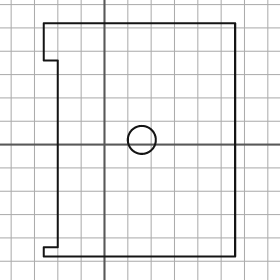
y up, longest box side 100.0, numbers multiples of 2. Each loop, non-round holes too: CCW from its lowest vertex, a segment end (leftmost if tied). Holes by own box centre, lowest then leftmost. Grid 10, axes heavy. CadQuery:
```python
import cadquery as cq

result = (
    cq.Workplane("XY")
    .moveTo(-26.0, -48.0)
    .lineTo(56.0, -48.0)
    .lineTo(56.0, 52.0)
    .lineTo(-26.0, 52.0)
    .lineTo(-26.0, 36.0)
    .lineTo(-20.0, 36.0)
    .lineTo(-20.0, -44.0)
    .lineTo(-26.0, -44.0)
    .close()
    .moveTo(16.0, 2.0)
    .circle(6.0)
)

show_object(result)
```